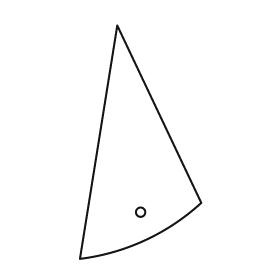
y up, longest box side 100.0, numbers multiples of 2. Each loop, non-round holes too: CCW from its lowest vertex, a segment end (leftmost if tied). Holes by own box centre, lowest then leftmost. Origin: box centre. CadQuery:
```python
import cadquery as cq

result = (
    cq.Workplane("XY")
    .moveTo(-26.0, -50.0)
    .threePointArc((2.0, -42.0), (26.0, -26.0))
    .lineTo(-10.0, 50.0)
    .close()
    .moveTo(0.0, -30.0)
    .circle(2.0)
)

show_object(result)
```